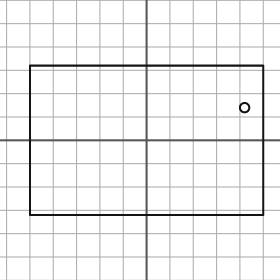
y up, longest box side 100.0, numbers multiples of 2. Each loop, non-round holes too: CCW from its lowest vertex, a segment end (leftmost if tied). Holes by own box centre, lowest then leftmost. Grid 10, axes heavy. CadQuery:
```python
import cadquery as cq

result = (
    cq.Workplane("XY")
    .moveTo(-50.0, -32.0)
    .lineTo(50.0, -32.0)
    .lineTo(50.0, 32.0)
    .lineTo(-50.0, 32.0)
    .close()
    .moveTo(42.0, 14.0)
    .circle(2.0)
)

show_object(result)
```